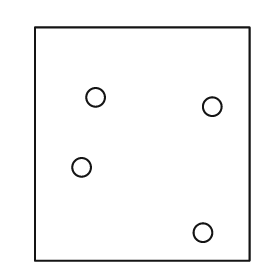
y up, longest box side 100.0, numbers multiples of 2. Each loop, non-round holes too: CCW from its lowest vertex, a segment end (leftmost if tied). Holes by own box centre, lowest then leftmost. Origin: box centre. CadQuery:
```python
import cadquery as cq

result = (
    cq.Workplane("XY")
    .moveTo(-46.0, -50.0)
    .lineTo(46.0, -50.0)
    .lineTo(46.0, 50.0)
    .lineTo(-46.0, 50.0)
    .close()
    .moveTo(26.0, -38.0)
    .circle(4.0)
    .moveTo(-26.0, -10.0)
    .circle(4.0)
    .moveTo(30.0, 16.0)
    .circle(4.0)
    .moveTo(-20.0, 20.0)
    .circle(4.0)
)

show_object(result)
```